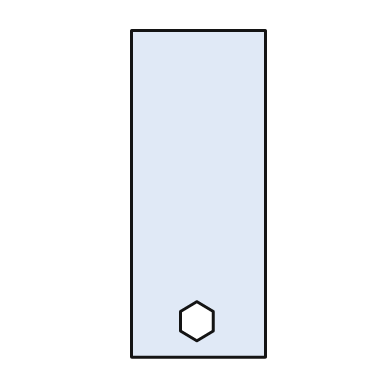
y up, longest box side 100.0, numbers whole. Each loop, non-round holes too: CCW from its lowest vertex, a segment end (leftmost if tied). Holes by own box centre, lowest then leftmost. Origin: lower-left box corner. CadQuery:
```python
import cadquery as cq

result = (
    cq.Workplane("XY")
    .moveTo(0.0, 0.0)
    .lineTo(41.0, 0.0)
    .lineTo(41.0, 100.0)
    .lineTo(0.0, 100.0)
    .close()
    .moveTo(20.0, 5.0)
    .lineTo(25.0, 8.0)
    .lineTo(25.0, 14.0)
    .lineTo(20.0, 17.0)
    .lineTo(15.0, 14.0)
    .lineTo(15.0, 8.0)
    .close()
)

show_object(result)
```